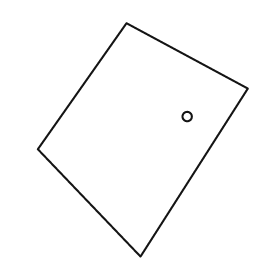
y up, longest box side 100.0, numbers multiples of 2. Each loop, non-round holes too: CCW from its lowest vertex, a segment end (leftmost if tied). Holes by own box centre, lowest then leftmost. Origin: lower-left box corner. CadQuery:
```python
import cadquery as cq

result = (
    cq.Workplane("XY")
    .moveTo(44.0, 0.0)
    .lineTo(90.0, 72.0)
    .lineTo(38.0, 100.0)
    .lineTo(0.0, 46.0)
    .close()
    .moveTo(64.0, 60.0)
    .circle(2.0)
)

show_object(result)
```